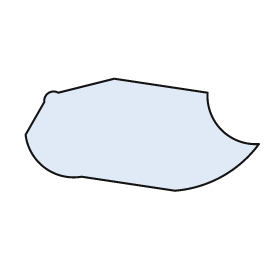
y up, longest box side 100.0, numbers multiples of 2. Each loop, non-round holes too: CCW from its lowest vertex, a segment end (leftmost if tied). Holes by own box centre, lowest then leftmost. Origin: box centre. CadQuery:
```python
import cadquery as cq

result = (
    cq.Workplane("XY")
    .moveTo(14.0, -24.0)
    .threePointArc((34.0, -18.0), (50.0, -4.0))
    .threePointArc((34.0, 2.0), (28.0, 18.0))
    .lineTo(-12.0, 24.0)
    .lineTo(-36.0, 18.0)
    .threePointArc((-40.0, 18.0), (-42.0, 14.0))
    .lineTo(-50.0, 0.0)
    .threePointArc((-42.0, -14.0), (-26.0, -18.0))
    .close()
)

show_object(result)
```